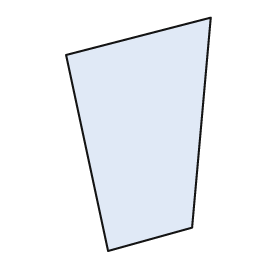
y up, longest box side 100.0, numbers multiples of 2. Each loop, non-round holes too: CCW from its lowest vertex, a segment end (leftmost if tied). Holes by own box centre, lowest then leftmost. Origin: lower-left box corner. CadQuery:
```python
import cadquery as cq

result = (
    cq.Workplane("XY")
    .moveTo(18.0, 0.0)
    .lineTo(54.0, 10.0)
    .lineTo(62.0, 100.0)
    .lineTo(0.0, 84.0)
    .close()
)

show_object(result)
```